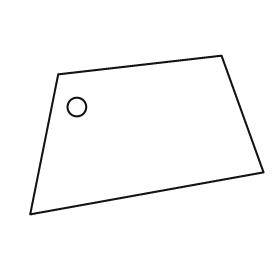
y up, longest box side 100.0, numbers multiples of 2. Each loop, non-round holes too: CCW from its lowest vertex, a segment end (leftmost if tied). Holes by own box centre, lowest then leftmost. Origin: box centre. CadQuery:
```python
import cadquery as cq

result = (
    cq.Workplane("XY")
    .moveTo(-50.0, -34.0)
    .lineTo(50.0, -16.0)
    .lineTo(32.0, 34.0)
    .lineTo(-38.0, 26.0)
    .close()
    .moveTo(-30.0, 12.0)
    .circle(4.0)
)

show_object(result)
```